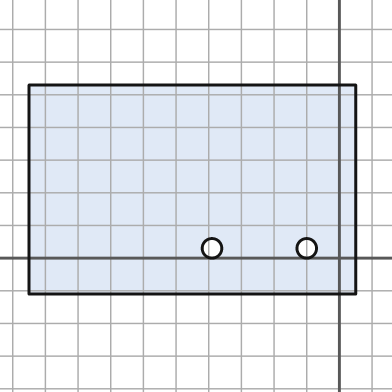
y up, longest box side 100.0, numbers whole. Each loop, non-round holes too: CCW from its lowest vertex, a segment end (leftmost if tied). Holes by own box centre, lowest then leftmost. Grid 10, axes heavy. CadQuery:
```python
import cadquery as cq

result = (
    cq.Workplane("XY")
    .moveTo(-95.0, -11.0)
    .lineTo(5.0, -11.0)
    .lineTo(5.0, 53.0)
    .lineTo(-95.0, 53.0)
    .close()
    .moveTo(-39.0, 3.0)
    .circle(3.0)
    .moveTo(-10.0, 3.0)
    .circle(3.0)
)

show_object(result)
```